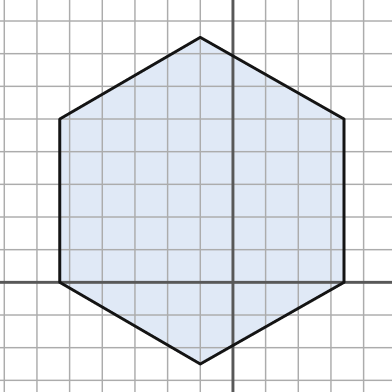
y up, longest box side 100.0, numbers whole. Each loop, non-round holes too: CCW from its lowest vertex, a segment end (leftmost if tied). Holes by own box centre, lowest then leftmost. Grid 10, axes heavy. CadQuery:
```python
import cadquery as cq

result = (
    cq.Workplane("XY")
    .moveTo(-10.0, -25.0)
    .lineTo(34.0, 0.0)
    .lineTo(34.0, 50.0)
    .lineTo(-10.0, 75.0)
    .lineTo(-53.0, 50.0)
    .lineTo(-53.0, 0.0)
    .close()
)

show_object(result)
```